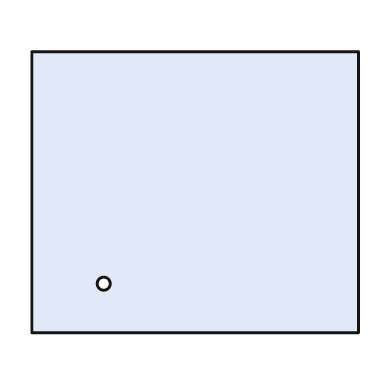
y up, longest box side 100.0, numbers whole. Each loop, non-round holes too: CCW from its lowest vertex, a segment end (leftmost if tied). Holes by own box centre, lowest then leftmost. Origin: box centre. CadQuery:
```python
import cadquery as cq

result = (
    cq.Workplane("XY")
    .moveTo(-50.0, -43.0)
    .lineTo(50.0, -43.0)
    .lineTo(50.0, 43.0)
    .lineTo(-50.0, 43.0)
    .close()
    .moveTo(-28.0, -28.0)
    .circle(2.0)
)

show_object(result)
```